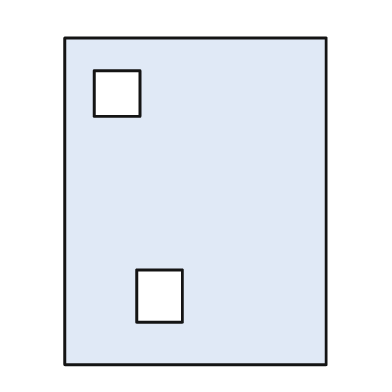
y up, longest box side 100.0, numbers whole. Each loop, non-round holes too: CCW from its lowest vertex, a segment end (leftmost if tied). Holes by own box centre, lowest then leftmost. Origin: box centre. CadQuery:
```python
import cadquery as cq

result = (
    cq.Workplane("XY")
    .moveTo(-40.0, -50.0)
    .lineTo(40.0, -50.0)
    .lineTo(40.0, 50.0)
    .lineTo(-40.0, 50.0)
    .close()
    .moveTo(-18.0, -37.0)
    .lineTo(-4.0, -37.0)
    .lineTo(-4.0, -21.0)
    .lineTo(-18.0, -21.0)
    .close()
    .moveTo(-31.0, 26.0)
    .lineTo(-17.0, 26.0)
    .lineTo(-17.0, 40.0)
    .lineTo(-31.0, 40.0)
    .close()
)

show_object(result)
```